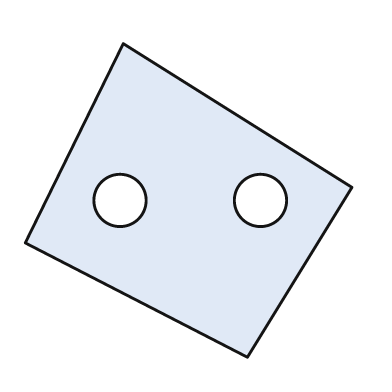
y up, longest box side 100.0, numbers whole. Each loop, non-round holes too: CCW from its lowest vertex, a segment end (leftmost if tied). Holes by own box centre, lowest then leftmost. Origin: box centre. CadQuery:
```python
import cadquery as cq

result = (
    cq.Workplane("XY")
    .moveTo(18.0, -48.0)
    .lineTo(50.0, 4.0)
    .lineTo(-20.0, 48.0)
    .lineTo(-50.0, -13.0)
    .close()
    .moveTo(-21.0, 0.0)
    .circle(8.0)
    .moveTo(22.0, 0.0)
    .circle(8.0)
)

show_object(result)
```